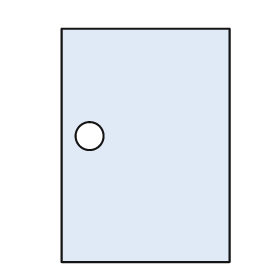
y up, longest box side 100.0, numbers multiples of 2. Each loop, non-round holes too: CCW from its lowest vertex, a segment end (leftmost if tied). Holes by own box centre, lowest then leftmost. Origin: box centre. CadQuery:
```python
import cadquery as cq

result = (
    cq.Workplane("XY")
    .moveTo(-36.0, -50.0)
    .lineTo(36.0, -50.0)
    .lineTo(36.0, 50.0)
    .lineTo(-36.0, 50.0)
    .close()
    .moveTo(-24.0, 4.0)
    .circle(6.0)
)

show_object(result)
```